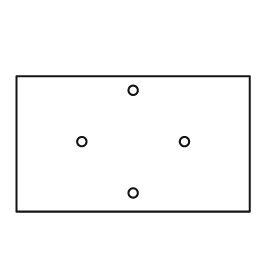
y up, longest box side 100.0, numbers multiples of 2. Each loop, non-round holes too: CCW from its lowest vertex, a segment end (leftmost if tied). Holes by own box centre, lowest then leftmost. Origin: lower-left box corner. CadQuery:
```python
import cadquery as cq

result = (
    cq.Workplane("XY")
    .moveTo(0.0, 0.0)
    .lineTo(100.0, 0.0)
    .lineTo(100.0, 58.0)
    .lineTo(0.0, 58.0)
    .close()
    .moveTo(50.0, 8.0)
    .circle(2.0)
    .moveTo(28.0, 30.0)
    .circle(2.0)
    .moveTo(72.0, 30.0)
    .circle(2.0)
    .moveTo(50.0, 52.0)
    .circle(2.0)
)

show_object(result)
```